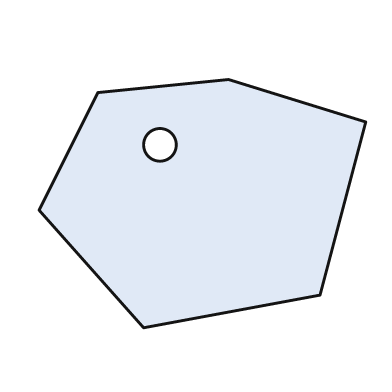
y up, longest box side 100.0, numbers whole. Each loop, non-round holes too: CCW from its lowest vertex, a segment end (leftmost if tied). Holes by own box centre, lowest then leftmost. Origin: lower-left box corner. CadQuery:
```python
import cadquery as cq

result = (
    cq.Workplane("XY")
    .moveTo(32.0, 0.0)
    .lineTo(86.0, 10.0)
    .lineTo(100.0, 63.0)
    .lineTo(58.0, 76.0)
    .lineTo(18.0, 72.0)
    .lineTo(0.0, 36.0)
    .close()
    .moveTo(37.0, 56.0)
    .circle(5.0)
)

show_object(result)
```